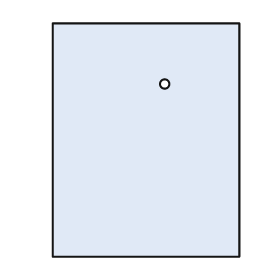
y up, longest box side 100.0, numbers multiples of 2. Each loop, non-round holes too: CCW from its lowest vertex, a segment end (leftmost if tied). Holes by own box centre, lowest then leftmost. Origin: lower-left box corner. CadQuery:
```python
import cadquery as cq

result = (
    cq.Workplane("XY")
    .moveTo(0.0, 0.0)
    .lineTo(80.0, 0.0)
    .lineTo(80.0, 100.0)
    .lineTo(0.0, 100.0)
    .close()
    .moveTo(48.0, 74.0)
    .circle(2.0)
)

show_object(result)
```